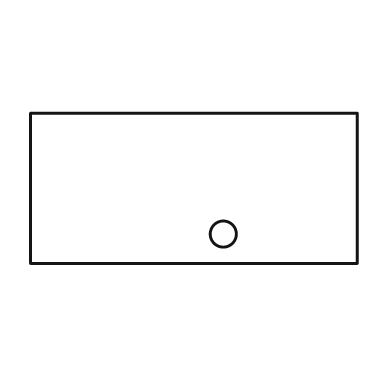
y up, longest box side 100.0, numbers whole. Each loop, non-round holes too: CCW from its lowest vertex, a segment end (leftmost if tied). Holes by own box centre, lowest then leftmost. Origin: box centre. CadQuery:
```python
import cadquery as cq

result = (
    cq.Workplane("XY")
    .moveTo(-50.0, -23.0)
    .lineTo(50.0, -23.0)
    .lineTo(50.0, 23.0)
    .lineTo(-50.0, 23.0)
    .close()
    .moveTo(9.0, -14.0)
    .circle(4.0)
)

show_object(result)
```